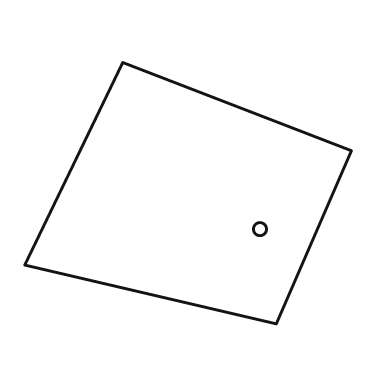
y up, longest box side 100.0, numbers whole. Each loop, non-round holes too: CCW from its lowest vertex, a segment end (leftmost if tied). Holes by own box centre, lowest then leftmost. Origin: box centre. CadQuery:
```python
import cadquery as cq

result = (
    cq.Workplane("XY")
    .moveTo(27.0, -40.0)
    .lineTo(50.0, 13.0)
    .lineTo(-20.0, 40.0)
    .lineTo(-50.0, -22.0)
    .close()
    .moveTo(22.0, -11.0)
    .circle(2.0)
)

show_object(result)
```